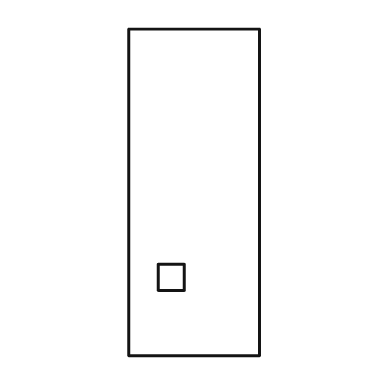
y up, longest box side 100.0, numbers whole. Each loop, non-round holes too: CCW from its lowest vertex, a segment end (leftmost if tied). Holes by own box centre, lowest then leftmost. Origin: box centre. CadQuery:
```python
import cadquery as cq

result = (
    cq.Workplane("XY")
    .moveTo(-20.0, -50.0)
    .lineTo(20.0, -50.0)
    .lineTo(20.0, 50.0)
    .lineTo(-20.0, 50.0)
    .close()
    .moveTo(-11.0, -30.0)
    .lineTo(-3.0, -30.0)
    .lineTo(-3.0, -22.0)
    .lineTo(-11.0, -22.0)
    .close()
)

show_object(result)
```